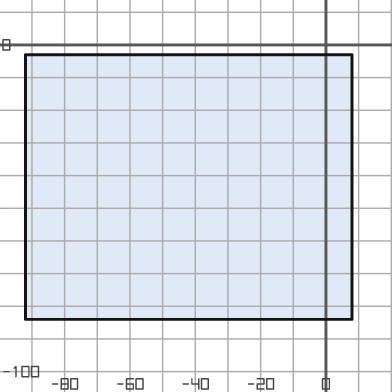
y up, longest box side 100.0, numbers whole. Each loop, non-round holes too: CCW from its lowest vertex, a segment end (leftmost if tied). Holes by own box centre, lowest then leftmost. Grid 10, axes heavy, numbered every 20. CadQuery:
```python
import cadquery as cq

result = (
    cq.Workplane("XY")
    .moveTo(-92.0, -84.0)
    .lineTo(8.0, -84.0)
    .lineTo(8.0, -3.0)
    .lineTo(-92.0, -3.0)
    .close()
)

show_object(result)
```